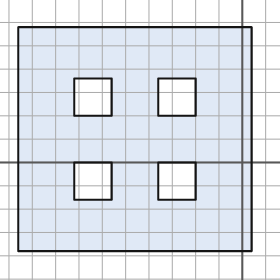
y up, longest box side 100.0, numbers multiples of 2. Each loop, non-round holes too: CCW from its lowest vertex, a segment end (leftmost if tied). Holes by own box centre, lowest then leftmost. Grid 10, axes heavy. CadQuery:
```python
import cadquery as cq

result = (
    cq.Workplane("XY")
    .moveTo(-96.0, -38.0)
    .lineTo(4.0, -38.0)
    .lineTo(4.0, 58.0)
    .lineTo(-96.0, 58.0)
    .close()
    .moveTo(-72.0, -16.0)
    .lineTo(-56.0, -16.0)
    .lineTo(-56.0, 0.0)
    .lineTo(-72.0, 0.0)
    .close()
    .moveTo(-36.0, -16.0)
    .lineTo(-20.0, -16.0)
    .lineTo(-20.0, 0.0)
    .lineTo(-36.0, 0.0)
    .close()
    .moveTo(-72.0, 20.0)
    .lineTo(-56.0, 20.0)
    .lineTo(-56.0, 36.0)
    .lineTo(-72.0, 36.0)
    .close()
    .moveTo(-36.0, 20.0)
    .lineTo(-20.0, 20.0)
    .lineTo(-20.0, 36.0)
    .lineTo(-36.0, 36.0)
    .close()
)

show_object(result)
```